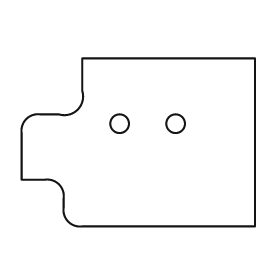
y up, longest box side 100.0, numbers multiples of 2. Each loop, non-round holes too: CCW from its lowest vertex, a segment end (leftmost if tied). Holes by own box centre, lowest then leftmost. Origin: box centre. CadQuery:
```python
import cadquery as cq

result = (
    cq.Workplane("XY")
    .moveTo(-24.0, -36.0)
    .lineTo(50.0, -36.0)
    .lineTo(50.0, 36.0)
    .lineTo(-24.0, 36.0)
    .lineTo(-24.0, 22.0)
    .threePointArc((-26.0, 14.0), (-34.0, 12.0))
    .lineTo(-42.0, 12.0)
    .threePointArc((-48.0, 10.0), (-50.0, 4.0))
    .lineTo(-50.0, -16.0)
    .lineTo(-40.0, -16.0)
    .threePointArc((-34.0, -18.0), (-32.0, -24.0))
    .lineTo(-32.0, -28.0)
    .threePointArc((-30.0, -34.0), (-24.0, -36.0))
    .close()
    .moveTo(-8.0, 8.0)
    .circle(4.0)
    .moveTo(16.0, 8.0)
    .circle(4.0)
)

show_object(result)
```